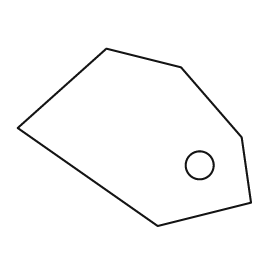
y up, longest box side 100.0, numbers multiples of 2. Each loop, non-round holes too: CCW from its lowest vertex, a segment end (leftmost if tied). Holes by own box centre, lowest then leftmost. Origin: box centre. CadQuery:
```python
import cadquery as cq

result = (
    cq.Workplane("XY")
    .moveTo(10.0, -38.0)
    .lineTo(50.0, -28.0)
    .lineTo(46.0, 0.0)
    .lineTo(20.0, 30.0)
    .lineTo(-12.0, 38.0)
    .lineTo(-50.0, 4.0)
    .close()
    .moveTo(28.0, -12.0)
    .circle(6.0)
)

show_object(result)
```